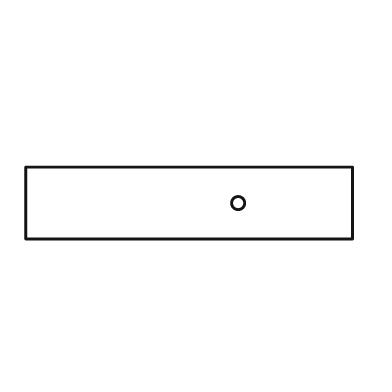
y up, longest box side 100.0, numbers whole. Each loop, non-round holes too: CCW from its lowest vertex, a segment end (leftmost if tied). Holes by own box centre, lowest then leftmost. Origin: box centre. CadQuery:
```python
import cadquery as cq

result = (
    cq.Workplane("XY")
    .moveTo(-50.0, -11.0)
    .lineTo(50.0, -11.0)
    .lineTo(50.0, 11.0)
    .lineTo(-50.0, 11.0)
    .close()
    .moveTo(15.0, 0.0)
    .circle(2.0)
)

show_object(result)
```